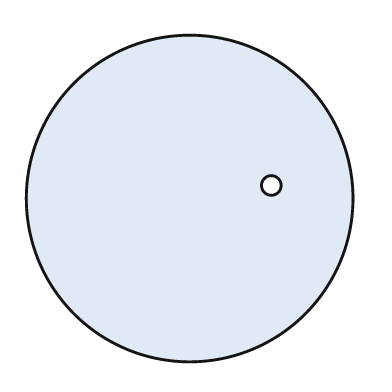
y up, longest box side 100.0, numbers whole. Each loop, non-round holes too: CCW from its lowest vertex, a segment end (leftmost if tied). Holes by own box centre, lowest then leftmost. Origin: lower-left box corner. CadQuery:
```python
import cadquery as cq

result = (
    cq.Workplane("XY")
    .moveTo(50.0, 50.0)
    .circle(50.0)
    .moveTo(75.0, 54.0)
    .circle(3.0)
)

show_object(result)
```